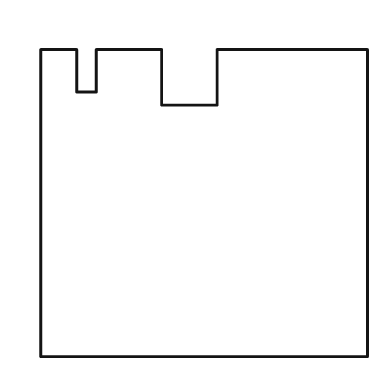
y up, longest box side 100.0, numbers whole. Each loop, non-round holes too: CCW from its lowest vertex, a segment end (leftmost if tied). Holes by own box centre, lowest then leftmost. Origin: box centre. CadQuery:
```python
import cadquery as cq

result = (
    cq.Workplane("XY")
    .moveTo(-50.0, -47.0)
    .lineTo(50.0, -47.0)
    .lineTo(50.0, 47.0)
    .lineTo(4.0, 47.0)
    .lineTo(4.0, 30.0)
    .lineTo(-13.0, 30.0)
    .lineTo(-13.0, 47.0)
    .lineTo(-33.0, 47.0)
    .lineTo(-33.0, 34.0)
    .lineTo(-39.0, 34.0)
    .lineTo(-39.0, 47.0)
    .lineTo(-50.0, 47.0)
    .close()
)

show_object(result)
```